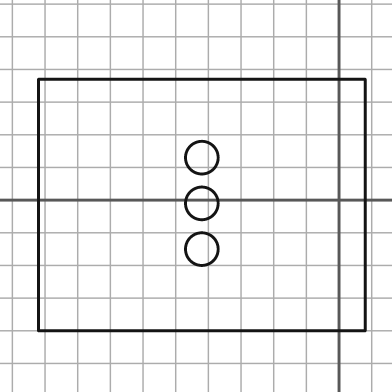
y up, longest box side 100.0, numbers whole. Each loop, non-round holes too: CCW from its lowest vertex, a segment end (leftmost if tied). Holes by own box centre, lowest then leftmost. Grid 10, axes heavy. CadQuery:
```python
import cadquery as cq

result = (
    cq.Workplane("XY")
    .moveTo(-92.0, -40.0)
    .lineTo(8.0, -40.0)
    .lineTo(8.0, 37.0)
    .lineTo(-92.0, 37.0)
    .close()
    .moveTo(-42.0, -15.0)
    .circle(5.0)
    .moveTo(-42.0, -1.0)
    .circle(5.0)
    .moveTo(-42.0, 13.0)
    .circle(5.0)
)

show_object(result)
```